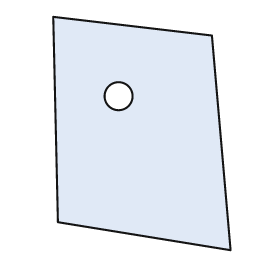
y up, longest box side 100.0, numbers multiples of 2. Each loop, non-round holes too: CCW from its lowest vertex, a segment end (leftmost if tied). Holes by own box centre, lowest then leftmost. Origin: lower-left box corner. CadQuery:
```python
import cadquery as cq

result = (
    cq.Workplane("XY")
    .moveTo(76.0, 0.0)
    .lineTo(68.0, 92.0)
    .lineTo(0.0, 100.0)
    .lineTo(2.0, 12.0)
    .close()
    .moveTo(28.0, 66.0)
    .circle(6.0)
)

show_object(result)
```